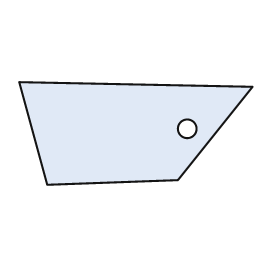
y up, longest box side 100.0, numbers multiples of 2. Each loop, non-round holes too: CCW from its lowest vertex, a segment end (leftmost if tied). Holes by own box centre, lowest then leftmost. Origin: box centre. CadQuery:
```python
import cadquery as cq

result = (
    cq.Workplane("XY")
    .moveTo(-38.0, -22.0)
    .lineTo(18.0, -20.0)
    .lineTo(50.0, 20.0)
    .lineTo(-50.0, 22.0)
    .close()
    .moveTo(22.0, 2.0)
    .circle(4.0)
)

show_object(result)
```